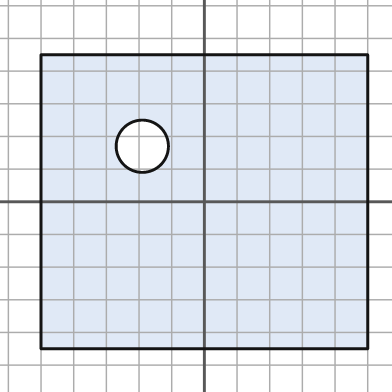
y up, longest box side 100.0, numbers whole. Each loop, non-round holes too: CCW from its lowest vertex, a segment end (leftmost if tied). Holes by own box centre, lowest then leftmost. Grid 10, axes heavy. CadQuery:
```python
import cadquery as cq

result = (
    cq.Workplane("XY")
    .moveTo(-50.0, -45.0)
    .lineTo(50.0, -45.0)
    .lineTo(50.0, 45.0)
    .lineTo(-50.0, 45.0)
    .close()
    .moveTo(-19.0, 17.0)
    .circle(8.0)
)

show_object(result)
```